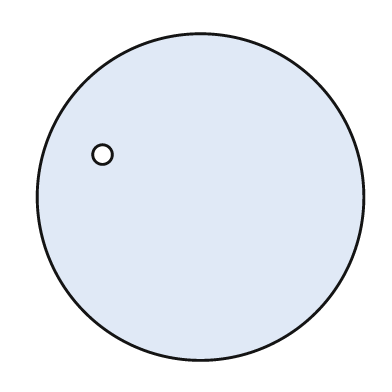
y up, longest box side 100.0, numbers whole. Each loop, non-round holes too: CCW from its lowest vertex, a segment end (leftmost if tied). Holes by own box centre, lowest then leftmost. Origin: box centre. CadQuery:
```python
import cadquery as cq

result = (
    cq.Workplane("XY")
    .moveTo(0.0, 0.0)
    .circle(50.0)
    .moveTo(-30.0, 13.0)
    .circle(3.0)
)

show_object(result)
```